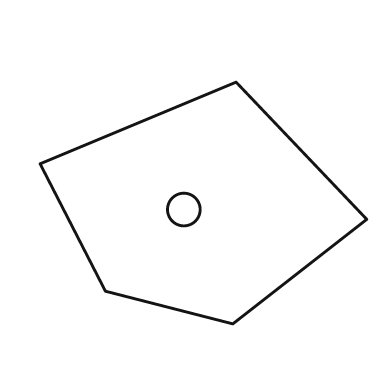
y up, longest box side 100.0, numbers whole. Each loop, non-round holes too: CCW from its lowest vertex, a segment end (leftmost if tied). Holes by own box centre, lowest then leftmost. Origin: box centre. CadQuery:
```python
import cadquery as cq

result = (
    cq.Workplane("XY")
    .moveTo(9.0, -37.0)
    .lineTo(50.0, -5.0)
    .lineTo(10.0, 37.0)
    .lineTo(-50.0, 12.0)
    .lineTo(-30.0, -27.0)
    .close()
    .moveTo(-6.0, -2.0)
    .circle(5.0)
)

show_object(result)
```